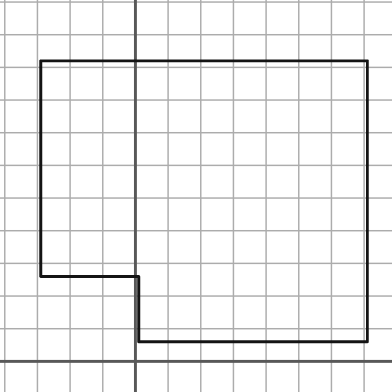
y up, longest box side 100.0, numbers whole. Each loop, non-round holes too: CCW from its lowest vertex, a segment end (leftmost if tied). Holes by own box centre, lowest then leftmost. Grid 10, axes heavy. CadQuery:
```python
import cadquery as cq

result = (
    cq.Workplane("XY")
    .moveTo(1.0, 6.0)
    .lineTo(71.0, 6.0)
    .lineTo(71.0, 92.0)
    .lineTo(-29.0, 92.0)
    .lineTo(-29.0, 26.0)
    .lineTo(1.0, 26.0)
    .close()
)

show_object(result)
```